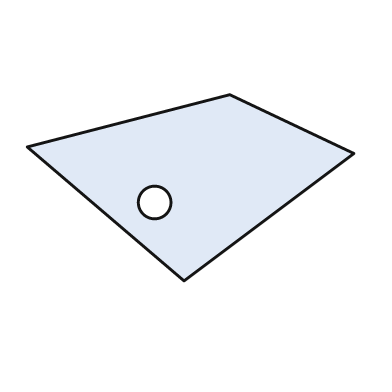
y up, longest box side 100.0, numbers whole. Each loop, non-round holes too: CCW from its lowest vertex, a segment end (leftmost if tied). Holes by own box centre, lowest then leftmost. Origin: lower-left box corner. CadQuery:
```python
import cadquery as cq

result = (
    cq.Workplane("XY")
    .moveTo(48.0, 0.0)
    .lineTo(100.0, 39.0)
    .lineTo(62.0, 57.0)
    .lineTo(0.0, 41.0)
    .close()
    .moveTo(39.0, 24.0)
    .circle(5.0)
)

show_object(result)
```